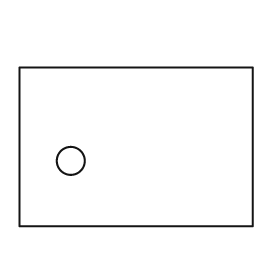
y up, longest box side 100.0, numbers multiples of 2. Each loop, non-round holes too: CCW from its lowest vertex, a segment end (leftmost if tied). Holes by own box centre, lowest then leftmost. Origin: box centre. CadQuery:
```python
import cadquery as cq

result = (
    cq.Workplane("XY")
    .moveTo(-50.0, -34.0)
    .lineTo(50.0, -34.0)
    .lineTo(50.0, 34.0)
    .lineTo(-50.0, 34.0)
    .close()
    .moveTo(-28.0, -6.0)
    .circle(6.0)
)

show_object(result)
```